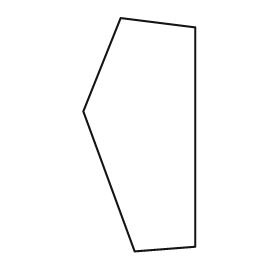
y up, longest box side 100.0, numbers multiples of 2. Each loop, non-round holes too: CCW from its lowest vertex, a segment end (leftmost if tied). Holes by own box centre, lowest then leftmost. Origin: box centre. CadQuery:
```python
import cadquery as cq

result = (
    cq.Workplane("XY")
    .moveTo(-2.0, -50.0)
    .lineTo(24.0, -48.0)
    .lineTo(24.0, 46.0)
    .lineTo(-8.0, 50.0)
    .lineTo(-24.0, 10.0)
    .close()
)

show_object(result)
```